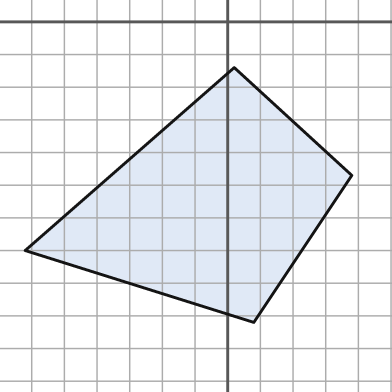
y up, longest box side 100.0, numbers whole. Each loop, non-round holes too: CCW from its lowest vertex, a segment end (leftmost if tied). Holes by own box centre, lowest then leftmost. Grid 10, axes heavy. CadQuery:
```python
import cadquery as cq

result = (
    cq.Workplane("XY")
    .moveTo(8.0, -92.0)
    .lineTo(38.0, -47.0)
    .lineTo(2.0, -14.0)
    .lineTo(-62.0, -70.0)
    .close()
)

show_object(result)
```